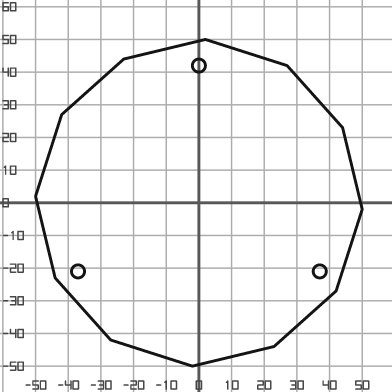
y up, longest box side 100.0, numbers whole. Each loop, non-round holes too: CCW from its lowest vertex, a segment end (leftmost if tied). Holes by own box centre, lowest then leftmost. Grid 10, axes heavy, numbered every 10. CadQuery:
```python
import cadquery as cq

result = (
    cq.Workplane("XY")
    .moveTo(-2.0, -50.0)
    .lineTo(23.0, -44.0)
    .lineTo(42.0, -27.0)
    .lineTo(50.0, -2.0)
    .lineTo(44.0, 23.0)
    .lineTo(27.0, 42.0)
    .lineTo(2.0, 50.0)
    .lineTo(-23.0, 44.0)
    .lineTo(-42.0, 27.0)
    .lineTo(-50.0, 2.0)
    .lineTo(-44.0, -23.0)
    .lineTo(-27.0, -42.0)
    .close()
    .moveTo(-37.0, -21.0)
    .circle(2.0)
    .moveTo(37.0, -21.0)
    .circle(2.0)
    .moveTo(0.0, 42.0)
    .circle(2.0)
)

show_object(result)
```